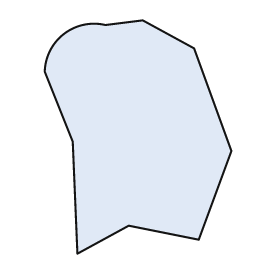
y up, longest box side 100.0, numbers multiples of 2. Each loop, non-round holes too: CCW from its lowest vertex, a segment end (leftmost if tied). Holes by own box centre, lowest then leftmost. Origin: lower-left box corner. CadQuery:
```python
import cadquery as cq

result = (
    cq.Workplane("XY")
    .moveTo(14.0, 0.0)
    .lineTo(36.0, 12.0)
    .lineTo(66.0, 6.0)
    .lineTo(80.0, 44.0)
    .lineTo(64.0, 88.0)
    .lineTo(42.0, 100.0)
    .lineTo(26.0, 98.0)
    .threePointArc((8.0, 94.0), (0.0, 78.0))
    .lineTo(12.0, 48.0)
    .close()
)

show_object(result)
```